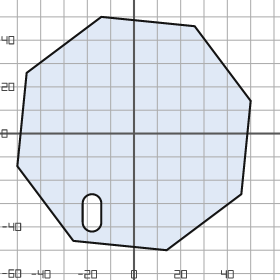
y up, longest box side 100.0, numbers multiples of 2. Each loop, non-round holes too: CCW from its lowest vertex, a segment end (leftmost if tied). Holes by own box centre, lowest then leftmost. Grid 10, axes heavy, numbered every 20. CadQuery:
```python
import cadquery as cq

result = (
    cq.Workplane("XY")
    .moveTo(14.0, -50.0)
    .lineTo(46.0, -26.0)
    .lineTo(50.0, 14.0)
    .lineTo(26.0, 46.0)
    .lineTo(-14.0, 50.0)
    .lineTo(-46.0, 26.0)
    .lineTo(-50.0, -14.0)
    .lineTo(-26.0, -46.0)
    .close()
    .moveTo(-22.0, -38.0)
    .threePointArc((-18.0, -42.0), (-14.0, -38.0))
    .lineTo(-14.0, -30.0)
    .threePointArc((-18.0, -26.0), (-22.0, -30.0))
    .close()
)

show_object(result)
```